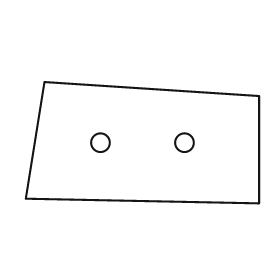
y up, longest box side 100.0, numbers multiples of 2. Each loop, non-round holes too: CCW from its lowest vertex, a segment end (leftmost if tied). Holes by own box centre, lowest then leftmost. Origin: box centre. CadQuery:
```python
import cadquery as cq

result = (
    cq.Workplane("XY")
    .moveTo(50.0, -26.0)
    .lineTo(50.0, 20.0)
    .lineTo(-42.0, 26.0)
    .lineTo(-50.0, -24.0)
    .close()
    .moveTo(-18.0, 0.0)
    .circle(4.0)
    .moveTo(18.0, 0.0)
    .circle(4.0)
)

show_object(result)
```